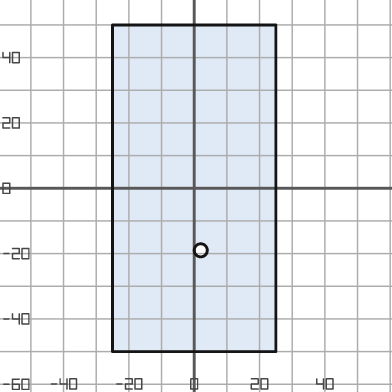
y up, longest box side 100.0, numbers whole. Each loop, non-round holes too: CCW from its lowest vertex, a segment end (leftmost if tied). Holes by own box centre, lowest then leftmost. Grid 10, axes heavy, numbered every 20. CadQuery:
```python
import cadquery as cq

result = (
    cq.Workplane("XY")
    .moveTo(-25.0, -50.0)
    .lineTo(25.0, -50.0)
    .lineTo(25.0, 50.0)
    .lineTo(-25.0, 50.0)
    .close()
    .moveTo(2.0, -19.0)
    .circle(2.0)
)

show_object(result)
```